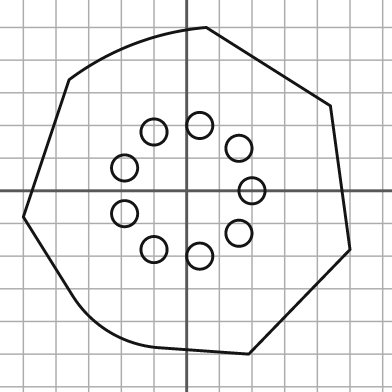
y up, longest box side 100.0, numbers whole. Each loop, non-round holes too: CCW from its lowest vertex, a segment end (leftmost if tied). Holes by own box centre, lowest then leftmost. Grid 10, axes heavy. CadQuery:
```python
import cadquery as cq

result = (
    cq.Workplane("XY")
    .moveTo(19.0, -50.0)
    .lineTo(50.0, -18.0)
    .lineTo(44.0, 26.0)
    .lineTo(6.0, 50.0)
    .threePointArc((-16.0, 45.0), (-36.0, 34.0))
    .lineTo(-50.0, -8.0)
    .lineTo(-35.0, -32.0)
    .threePointArc((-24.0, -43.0), (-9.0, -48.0))
    .close()
    .moveTo(4.0, -20.0)
    .circle(4.0)
    .moveTo(-10.0, -18.0)
    .circle(4.0)
    .moveTo(16.0, -13.0)
    .circle(4.0)
    .moveTo(-19.0, -7.0)
    .circle(4.0)
    .moveTo(20.0, 0.0)
    .circle(4.0)
    .moveTo(-19.0, 7.0)
    .circle(4.0)
    .moveTo(16.0, 13.0)
    .circle(4.0)
    .moveTo(-10.0, 18.0)
    .circle(4.0)
    .moveTo(4.0, 20.0)
    .circle(4.0)
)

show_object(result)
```